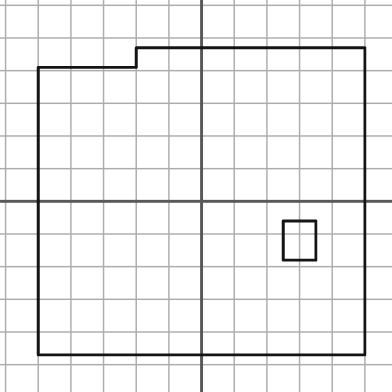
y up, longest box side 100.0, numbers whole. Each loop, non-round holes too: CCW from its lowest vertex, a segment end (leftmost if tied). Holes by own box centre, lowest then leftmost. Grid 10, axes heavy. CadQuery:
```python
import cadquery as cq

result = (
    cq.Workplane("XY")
    .moveTo(-50.0, -47.0)
    .lineTo(50.0, -47.0)
    .lineTo(50.0, 47.0)
    .lineTo(-20.0, 47.0)
    .lineTo(-20.0, 41.0)
    .lineTo(-50.0, 41.0)
    .close()
    .moveTo(25.0, -18.0)
    .lineTo(35.0, -18.0)
    .lineTo(35.0, -6.0)
    .lineTo(25.0, -6.0)
    .close()
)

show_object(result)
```